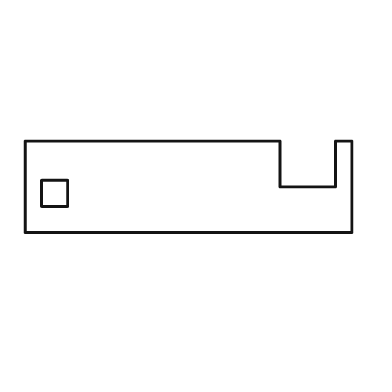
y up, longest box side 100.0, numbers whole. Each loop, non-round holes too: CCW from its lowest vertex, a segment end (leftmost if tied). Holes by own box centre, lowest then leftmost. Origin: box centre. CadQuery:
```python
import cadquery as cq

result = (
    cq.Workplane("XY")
    .moveTo(-50.0, -14.0)
    .lineTo(50.0, -14.0)
    .lineTo(50.0, 14.0)
    .lineTo(45.0, 14.0)
    .lineTo(45.0, 0.0)
    .lineTo(28.0, 0.0)
    .lineTo(28.0, 14.0)
    .lineTo(-50.0, 14.0)
    .close()
    .moveTo(-45.0, -6.0)
    .lineTo(-37.0, -6.0)
    .lineTo(-37.0, 2.0)
    .lineTo(-45.0, 2.0)
    .close()
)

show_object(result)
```